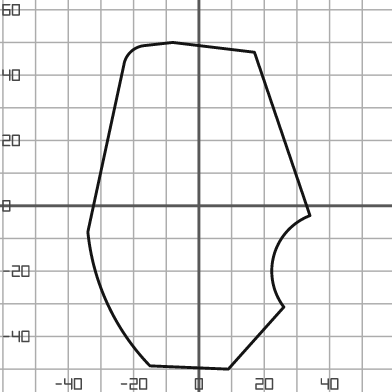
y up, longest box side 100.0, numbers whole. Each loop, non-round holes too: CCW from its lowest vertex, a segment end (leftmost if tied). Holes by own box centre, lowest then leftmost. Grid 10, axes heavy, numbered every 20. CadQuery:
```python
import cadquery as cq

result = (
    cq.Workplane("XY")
    .moveTo(9.0, -50.0)
    .lineTo(26.0, -31.0)
    .threePointArc((23.0, -15.0), (34.0, -3.0))
    .lineTo(17.0, 47.0)
    .lineTo(-8.0, 50.0)
    .lineTo(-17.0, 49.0)
    .threePointArc((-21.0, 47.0), (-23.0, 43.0))
    .lineTo(-34.0, -8.0)
    .threePointArc((-28.0, -30.0), (-15.0, -49.0))
    .close()
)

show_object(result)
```